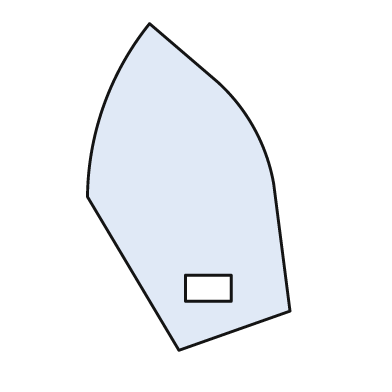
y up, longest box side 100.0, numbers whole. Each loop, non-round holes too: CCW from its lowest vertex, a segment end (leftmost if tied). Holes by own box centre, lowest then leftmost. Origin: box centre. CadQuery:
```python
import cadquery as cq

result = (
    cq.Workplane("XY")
    .moveTo(-3.0, -50.0)
    .lineTo(31.0, -38.0)
    .lineTo(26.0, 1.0)
    .threePointArc((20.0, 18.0), (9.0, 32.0))
    .lineTo(-12.0, 50.0)
    .threePointArc((-26.0, 25.0), (-31.0, -3.0))
    .close()
    .moveTo(-1.0, -35.0)
    .lineTo(13.0, -35.0)
    .lineTo(13.0, -27.0)
    .lineTo(-1.0, -27.0)
    .close()
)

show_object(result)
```